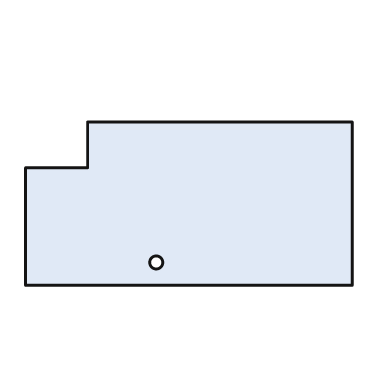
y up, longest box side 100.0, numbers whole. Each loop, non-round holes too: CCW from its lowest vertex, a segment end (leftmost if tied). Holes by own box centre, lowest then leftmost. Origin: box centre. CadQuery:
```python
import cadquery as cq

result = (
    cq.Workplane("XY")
    .moveTo(-50.0, -25.0)
    .lineTo(50.0, -25.0)
    .lineTo(50.0, 25.0)
    .lineTo(-31.0, 25.0)
    .lineTo(-31.0, 11.0)
    .lineTo(-50.0, 11.0)
    .close()
    .moveTo(-10.0, -18.0)
    .circle(2.0)
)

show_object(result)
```